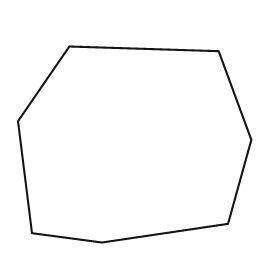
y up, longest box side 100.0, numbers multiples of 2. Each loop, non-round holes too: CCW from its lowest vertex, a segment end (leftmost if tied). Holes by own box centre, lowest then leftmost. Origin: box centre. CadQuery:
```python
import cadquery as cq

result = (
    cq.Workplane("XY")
    .moveTo(-14.0, -42.0)
    .lineTo(40.0, -34.0)
    .lineTo(50.0, 2.0)
    .lineTo(36.0, 40.0)
    .lineTo(-28.0, 42.0)
    .lineTo(-50.0, 10.0)
    .lineTo(-44.0, -38.0)
    .close()
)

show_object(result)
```